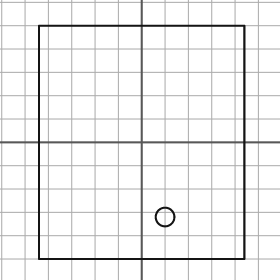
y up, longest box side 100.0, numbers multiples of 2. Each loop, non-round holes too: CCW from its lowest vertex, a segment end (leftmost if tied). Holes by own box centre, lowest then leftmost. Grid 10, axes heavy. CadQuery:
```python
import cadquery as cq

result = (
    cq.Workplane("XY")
    .moveTo(-44.0, -50.0)
    .lineTo(44.0, -50.0)
    .lineTo(44.0, 50.0)
    .lineTo(-44.0, 50.0)
    .close()
    .moveTo(10.0, -32.0)
    .circle(4.0)
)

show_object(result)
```